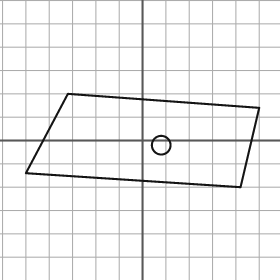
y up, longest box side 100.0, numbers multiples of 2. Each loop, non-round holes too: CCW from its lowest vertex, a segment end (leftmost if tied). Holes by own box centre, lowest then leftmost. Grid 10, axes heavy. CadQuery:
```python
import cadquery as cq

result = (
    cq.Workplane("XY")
    .moveTo(42.0, -20.0)
    .lineTo(50.0, 14.0)
    .lineTo(-32.0, 20.0)
    .lineTo(-50.0, -14.0)
    .close()
    .moveTo(8.0, -2.0)
    .circle(4.0)
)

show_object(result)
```